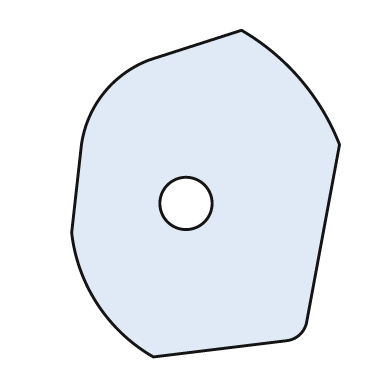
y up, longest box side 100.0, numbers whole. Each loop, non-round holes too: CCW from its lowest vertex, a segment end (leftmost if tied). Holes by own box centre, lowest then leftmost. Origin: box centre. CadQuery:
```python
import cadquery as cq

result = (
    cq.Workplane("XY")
    .moveTo(-16.0, -50.0)
    .lineTo(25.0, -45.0)
    .threePointArc((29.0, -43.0), (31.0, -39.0))
    .lineTo(41.0, 15.0)
    .threePointArc((29.0, 35.0), (11.0, 50.0))
    .lineTo(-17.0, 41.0)
    .threePointArc((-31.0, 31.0), (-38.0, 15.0))
    .lineTo(-41.0, -12.0)
    .threePointArc((-33.0, -34.0), (-16.0, -50.0))
    .close()
    .moveTo(-6.0, -3.0)
    .circle(8.0)
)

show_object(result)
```